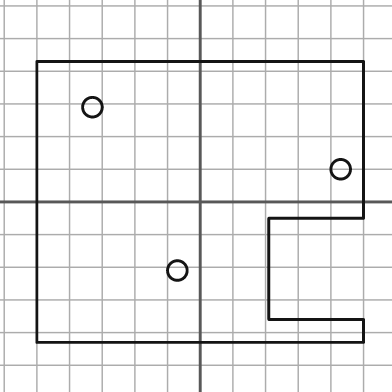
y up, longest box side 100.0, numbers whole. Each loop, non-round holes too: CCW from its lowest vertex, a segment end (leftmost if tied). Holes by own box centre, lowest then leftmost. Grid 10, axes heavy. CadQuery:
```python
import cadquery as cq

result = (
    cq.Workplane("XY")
    .moveTo(-50.0, -43.0)
    .lineTo(50.0, -43.0)
    .lineTo(50.0, -36.0)
    .lineTo(21.0, -36.0)
    .lineTo(21.0, -5.0)
    .lineTo(50.0, -5.0)
    .lineTo(50.0, 43.0)
    .lineTo(-50.0, 43.0)
    .close()
    .moveTo(-7.0, -21.0)
    .circle(3.0)
    .moveTo(43.0, 10.0)
    .circle(3.0)
    .moveTo(-33.0, 29.0)
    .circle(3.0)
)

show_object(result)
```